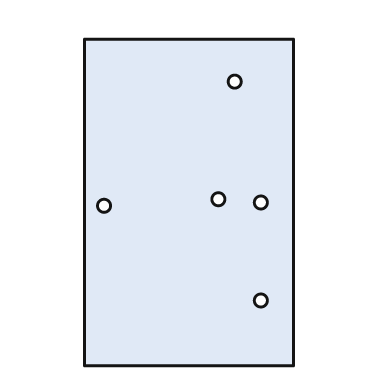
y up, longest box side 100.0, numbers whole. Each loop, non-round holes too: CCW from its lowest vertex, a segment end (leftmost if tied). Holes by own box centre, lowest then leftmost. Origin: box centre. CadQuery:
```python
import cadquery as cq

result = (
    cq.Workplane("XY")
    .moveTo(-32.0, -50.0)
    .lineTo(32.0, -50.0)
    .lineTo(32.0, 50.0)
    .lineTo(-32.0, 50.0)
    .close()
    .moveTo(22.0, -30.0)
    .circle(2.0)
    .moveTo(-26.0, -1.0)
    .circle(2.0)
    .moveTo(22.0, 0.0)
    .circle(2.0)
    .moveTo(9.0, 1.0)
    .circle(2.0)
    .moveTo(14.0, 37.0)
    .circle(2.0)
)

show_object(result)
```